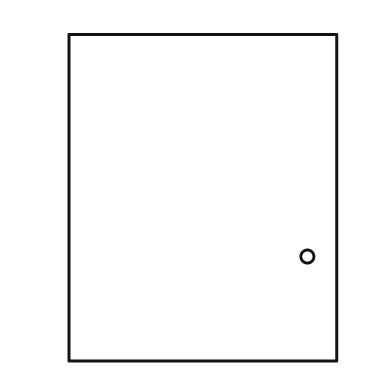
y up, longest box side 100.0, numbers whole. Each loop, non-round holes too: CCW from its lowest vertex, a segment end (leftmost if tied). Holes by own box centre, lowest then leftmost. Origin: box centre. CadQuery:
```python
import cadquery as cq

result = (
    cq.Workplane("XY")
    .moveTo(-41.0, -50.0)
    .lineTo(41.0, -50.0)
    .lineTo(41.0, 50.0)
    .lineTo(-41.0, 50.0)
    .close()
    .moveTo(32.0, -18.0)
    .circle(2.0)
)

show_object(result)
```